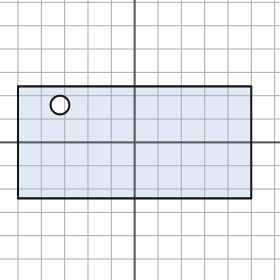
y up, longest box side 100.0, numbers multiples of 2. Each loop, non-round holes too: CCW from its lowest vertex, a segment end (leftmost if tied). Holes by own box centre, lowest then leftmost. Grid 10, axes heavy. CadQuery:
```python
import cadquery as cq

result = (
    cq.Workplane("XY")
    .moveTo(-50.0, -24.0)
    .lineTo(50.0, -24.0)
    .lineTo(50.0, 24.0)
    .lineTo(-50.0, 24.0)
    .close()
    .moveTo(-32.0, 16.0)
    .circle(4.0)
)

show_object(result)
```